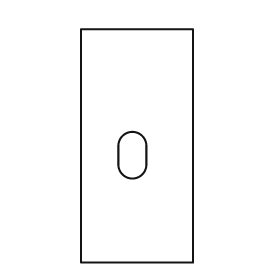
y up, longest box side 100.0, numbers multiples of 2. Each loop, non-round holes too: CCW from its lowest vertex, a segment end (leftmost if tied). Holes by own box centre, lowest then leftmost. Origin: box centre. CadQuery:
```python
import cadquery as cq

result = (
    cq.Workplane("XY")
    .moveTo(-24.0, -50.0)
    .lineTo(24.0, -50.0)
    .lineTo(24.0, 50.0)
    .lineTo(-24.0, 50.0)
    .close()
    .moveTo(-8.0, -8.0)
    .threePointArc((-2.0, -14.0), (4.0, -8.0))
    .lineTo(4.0, 0.0)
    .threePointArc((-2.0, 6.0), (-8.0, 0.0))
    .close()
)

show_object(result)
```